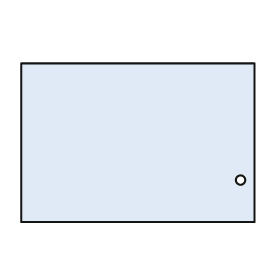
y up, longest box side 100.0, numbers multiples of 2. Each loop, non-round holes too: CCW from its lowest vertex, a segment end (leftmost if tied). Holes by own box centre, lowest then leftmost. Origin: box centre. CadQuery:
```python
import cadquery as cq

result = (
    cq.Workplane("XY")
    .moveTo(-50.0, -34.0)
    .lineTo(50.0, -34.0)
    .lineTo(50.0, 34.0)
    .lineTo(-50.0, 34.0)
    .close()
    .moveTo(44.0, -16.0)
    .circle(2.0)
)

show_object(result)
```